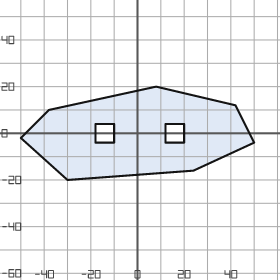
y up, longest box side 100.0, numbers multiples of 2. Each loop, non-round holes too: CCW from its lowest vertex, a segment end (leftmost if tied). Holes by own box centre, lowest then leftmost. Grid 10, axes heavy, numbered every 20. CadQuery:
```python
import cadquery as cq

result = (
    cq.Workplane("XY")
    .moveTo(-30.0, -20.0)
    .lineTo(24.0, -16.0)
    .lineTo(50.0, -4.0)
    .lineTo(42.0, 12.0)
    .lineTo(8.0, 20.0)
    .lineTo(-38.0, 10.0)
    .lineTo(-50.0, -2.0)
    .close()
    .moveTo(-18.0, -4.0)
    .lineTo(-10.0, -4.0)
    .lineTo(-10.0, 4.0)
    .lineTo(-18.0, 4.0)
    .close()
    .moveTo(12.0, -4.0)
    .lineTo(20.0, -4.0)
    .lineTo(20.0, 4.0)
    .lineTo(12.0, 4.0)
    .close()
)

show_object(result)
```